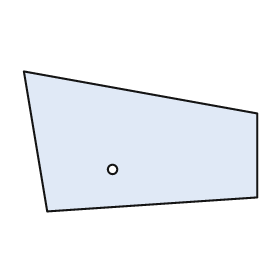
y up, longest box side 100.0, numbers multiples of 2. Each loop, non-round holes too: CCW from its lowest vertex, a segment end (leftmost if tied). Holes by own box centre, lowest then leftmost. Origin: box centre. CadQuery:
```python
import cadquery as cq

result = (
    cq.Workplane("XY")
    .moveTo(-40.0, -30.0)
    .lineTo(50.0, -24.0)
    .lineTo(50.0, 12.0)
    .lineTo(-50.0, 30.0)
    .close()
    .moveTo(-12.0, -12.0)
    .circle(2.0)
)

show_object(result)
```